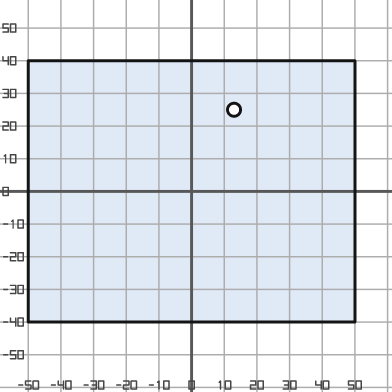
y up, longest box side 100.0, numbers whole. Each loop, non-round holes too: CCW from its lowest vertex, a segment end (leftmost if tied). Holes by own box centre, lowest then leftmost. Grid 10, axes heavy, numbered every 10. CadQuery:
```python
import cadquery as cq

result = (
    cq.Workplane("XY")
    .moveTo(-50.0, -40.0)
    .lineTo(50.0, -40.0)
    .lineTo(50.0, 40.0)
    .lineTo(-50.0, 40.0)
    .close()
    .moveTo(13.0, 25.0)
    .circle(2.0)
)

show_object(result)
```